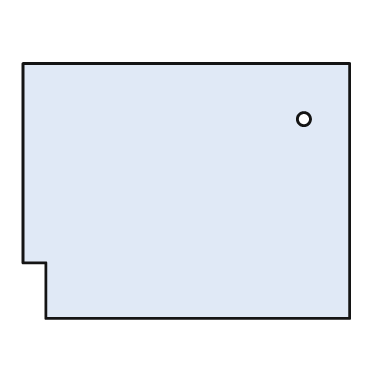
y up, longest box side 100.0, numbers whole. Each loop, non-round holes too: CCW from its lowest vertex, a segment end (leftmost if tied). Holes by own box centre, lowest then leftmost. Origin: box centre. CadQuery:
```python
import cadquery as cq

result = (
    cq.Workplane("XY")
    .moveTo(-43.0, -39.0)
    .lineTo(50.0, -39.0)
    .lineTo(50.0, 39.0)
    .lineTo(-50.0, 39.0)
    .lineTo(-50.0, -22.0)
    .lineTo(-43.0, -22.0)
    .close()
    .moveTo(36.0, 22.0)
    .circle(2.0)
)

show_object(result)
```